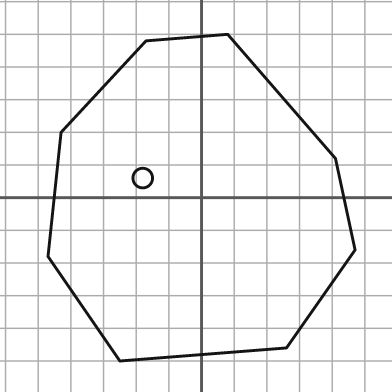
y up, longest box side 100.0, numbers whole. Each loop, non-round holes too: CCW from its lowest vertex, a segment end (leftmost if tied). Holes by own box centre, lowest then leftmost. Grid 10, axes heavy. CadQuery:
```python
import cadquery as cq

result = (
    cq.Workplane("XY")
    .moveTo(-25.0, -50.0)
    .lineTo(26.0, -46.0)
    .lineTo(47.0, -16.0)
    .lineTo(41.0, 12.0)
    .lineTo(8.0, 50.0)
    .lineTo(-17.0, 48.0)
    .lineTo(-43.0, 20.0)
    .lineTo(-47.0, -18.0)
    .close()
    .moveTo(-18.0, 6.0)
    .circle(3.0)
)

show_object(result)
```